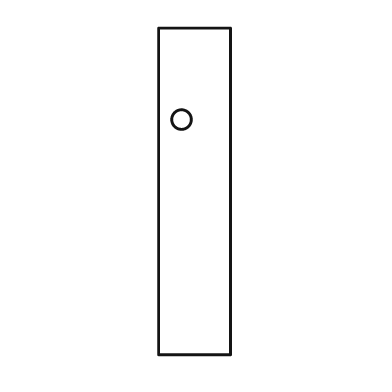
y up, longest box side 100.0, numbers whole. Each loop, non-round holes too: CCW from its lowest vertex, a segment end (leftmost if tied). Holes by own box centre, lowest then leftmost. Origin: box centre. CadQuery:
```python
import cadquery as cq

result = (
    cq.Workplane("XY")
    .moveTo(-11.0, -50.0)
    .lineTo(11.0, -50.0)
    .lineTo(11.0, 50.0)
    .lineTo(-11.0, 50.0)
    .close()
    .moveTo(-4.0, 22.0)
    .circle(3.0)
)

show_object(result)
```